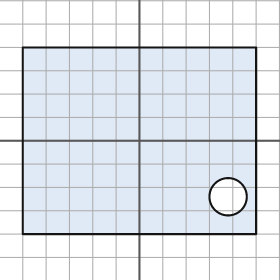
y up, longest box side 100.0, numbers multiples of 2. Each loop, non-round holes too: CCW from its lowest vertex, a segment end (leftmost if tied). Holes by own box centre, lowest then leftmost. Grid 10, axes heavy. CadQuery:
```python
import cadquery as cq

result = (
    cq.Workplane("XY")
    .moveTo(-50.0, -40.0)
    .lineTo(50.0, -40.0)
    .lineTo(50.0, 40.0)
    .lineTo(-50.0, 40.0)
    .close()
    .moveTo(38.0, -24.0)
    .circle(8.0)
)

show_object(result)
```